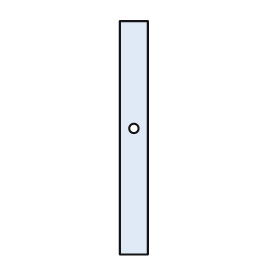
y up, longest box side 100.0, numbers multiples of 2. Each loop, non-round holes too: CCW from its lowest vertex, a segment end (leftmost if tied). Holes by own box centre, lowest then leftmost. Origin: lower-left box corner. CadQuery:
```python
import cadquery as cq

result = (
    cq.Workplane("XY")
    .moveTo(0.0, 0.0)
    .lineTo(12.0, 0.0)
    .lineTo(12.0, 100.0)
    .lineTo(0.0, 100.0)
    .close()
    .moveTo(6.0, 54.0)
    .circle(2.0)
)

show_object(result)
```